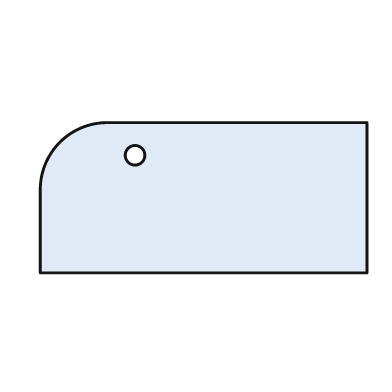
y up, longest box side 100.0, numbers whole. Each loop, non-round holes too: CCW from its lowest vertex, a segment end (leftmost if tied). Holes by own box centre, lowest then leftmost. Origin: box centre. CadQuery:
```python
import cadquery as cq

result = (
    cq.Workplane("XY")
    .moveTo(-50.0, -23.0)
    .lineTo(50.0, -23.0)
    .lineTo(50.0, 23.0)
    .lineTo(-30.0, 23.0)
    .threePointArc((-44.0, 17.0), (-50.0, 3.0))
    .close()
    .moveTo(-21.0, 13.0)
    .circle(3.0)
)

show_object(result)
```